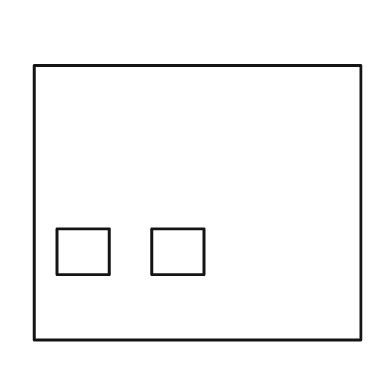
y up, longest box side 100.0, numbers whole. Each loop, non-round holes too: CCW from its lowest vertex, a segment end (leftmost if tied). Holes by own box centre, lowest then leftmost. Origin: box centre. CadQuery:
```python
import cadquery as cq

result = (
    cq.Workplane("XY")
    .moveTo(-50.0, -42.0)
    .lineTo(50.0, -42.0)
    .lineTo(50.0, 42.0)
    .lineTo(-50.0, 42.0)
    .close()
    .moveTo(-43.0, -22.0)
    .lineTo(-27.0, -22.0)
    .lineTo(-27.0, -8.0)
    .lineTo(-43.0, -8.0)
    .close()
    .moveTo(-14.0, -22.0)
    .lineTo(2.0, -22.0)
    .lineTo(2.0, -8.0)
    .lineTo(-14.0, -8.0)
    .close()
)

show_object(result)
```